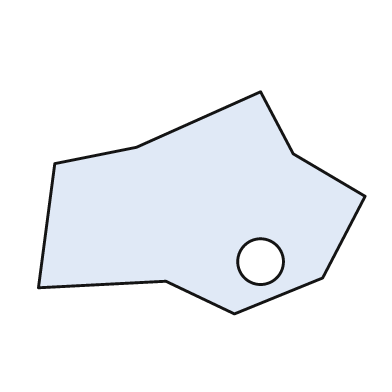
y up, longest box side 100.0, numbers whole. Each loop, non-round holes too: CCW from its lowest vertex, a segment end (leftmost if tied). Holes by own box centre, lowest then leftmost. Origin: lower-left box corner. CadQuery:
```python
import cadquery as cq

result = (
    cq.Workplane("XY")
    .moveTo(60.0, 0.0)
    .lineTo(87.0, 11.0)
    .lineTo(100.0, 36.0)
    .lineTo(78.0, 49.0)
    .lineTo(68.0, 68.0)
    .lineTo(30.0, 51.0)
    .lineTo(5.0, 46.0)
    .lineTo(0.0, 8.0)
    .lineTo(39.0, 10.0)
    .close()
    .moveTo(68.0, 16.0)
    .circle(7.0)
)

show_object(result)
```